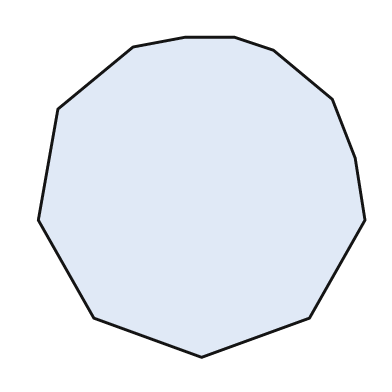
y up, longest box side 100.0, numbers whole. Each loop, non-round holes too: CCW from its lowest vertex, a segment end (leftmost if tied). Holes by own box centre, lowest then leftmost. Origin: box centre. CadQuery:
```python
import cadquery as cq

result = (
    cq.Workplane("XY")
    .moveTo(0.0, -49.0)
    .lineTo(33.0, -37.0)
    .lineTo(50.0, -7.0)
    .lineTo(47.0, 12.0)
    .lineTo(40.0, 30.0)
    .lineTo(22.0, 45.0)
    .lineTo(10.0, 49.0)
    .lineTo(-5.0, 49.0)
    .lineTo(-21.0, 46.0)
    .lineTo(-44.0, 27.0)
    .lineTo(-50.0, -7.0)
    .lineTo(-33.0, -37.0)
    .close()
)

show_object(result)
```